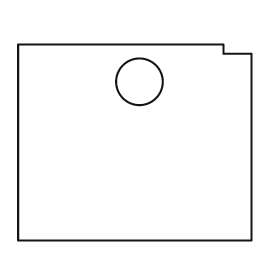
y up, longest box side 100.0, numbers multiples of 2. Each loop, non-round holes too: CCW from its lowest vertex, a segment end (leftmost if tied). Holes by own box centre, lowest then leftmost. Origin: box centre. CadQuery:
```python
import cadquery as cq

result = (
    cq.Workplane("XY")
    .moveTo(-50.0, -42.0)
    .lineTo(50.0, -42.0)
    .lineTo(50.0, 38.0)
    .lineTo(38.0, 38.0)
    .lineTo(38.0, 42.0)
    .lineTo(-50.0, 42.0)
    .close()
    .moveTo(2.0, 26.0)
    .circle(10.0)
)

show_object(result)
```